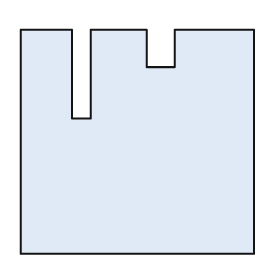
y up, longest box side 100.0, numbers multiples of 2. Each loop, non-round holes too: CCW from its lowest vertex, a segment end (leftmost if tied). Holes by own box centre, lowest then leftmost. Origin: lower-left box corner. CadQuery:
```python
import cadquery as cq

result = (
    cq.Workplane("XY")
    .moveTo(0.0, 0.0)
    .lineTo(100.0, 0.0)
    .lineTo(100.0, 96.0)
    .lineTo(66.0, 96.0)
    .lineTo(66.0, 80.0)
    .lineTo(54.0, 80.0)
    .lineTo(54.0, 96.0)
    .lineTo(30.0, 96.0)
    .lineTo(30.0, 58.0)
    .lineTo(22.0, 58.0)
    .lineTo(22.0, 96.0)
    .lineTo(0.0, 96.0)
    .close()
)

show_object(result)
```